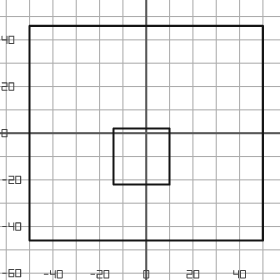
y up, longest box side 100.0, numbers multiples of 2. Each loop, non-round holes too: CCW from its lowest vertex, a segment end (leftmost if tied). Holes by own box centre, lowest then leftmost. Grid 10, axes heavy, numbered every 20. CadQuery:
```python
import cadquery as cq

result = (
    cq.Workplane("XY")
    .moveTo(-50.0, -46.0)
    .lineTo(50.0, -46.0)
    .lineTo(50.0, 46.0)
    .lineTo(-50.0, 46.0)
    .close()
    .moveTo(-14.0, -22.0)
    .lineTo(10.0, -22.0)
    .lineTo(10.0, 2.0)
    .lineTo(-14.0, 2.0)
    .close()
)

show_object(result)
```